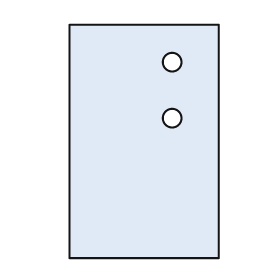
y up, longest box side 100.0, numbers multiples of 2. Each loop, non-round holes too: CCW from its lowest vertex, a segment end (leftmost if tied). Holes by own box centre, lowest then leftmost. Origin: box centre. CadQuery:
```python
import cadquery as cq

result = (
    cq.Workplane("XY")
    .moveTo(-32.0, -50.0)
    .lineTo(32.0, -50.0)
    .lineTo(32.0, 50.0)
    .lineTo(-32.0, 50.0)
    .close()
    .moveTo(12.0, 10.0)
    .circle(4.0)
    .moveTo(12.0, 34.0)
    .circle(4.0)
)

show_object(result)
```